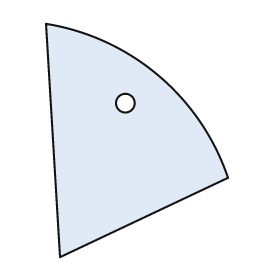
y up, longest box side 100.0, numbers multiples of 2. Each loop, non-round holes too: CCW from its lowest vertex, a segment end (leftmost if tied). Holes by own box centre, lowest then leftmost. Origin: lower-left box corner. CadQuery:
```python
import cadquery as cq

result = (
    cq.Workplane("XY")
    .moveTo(6.0, 0.0)
    .lineTo(78.0, 34.0)
    .threePointArc((48.0, 78.0), (0.0, 100.0))
    .close()
    .moveTo(34.0, 66.0)
    .circle(4.0)
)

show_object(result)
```